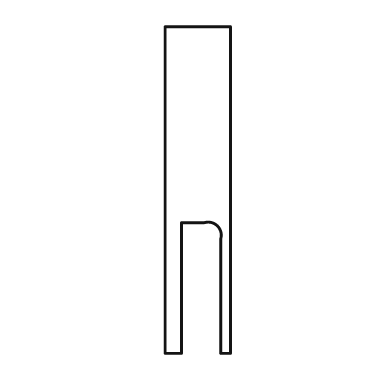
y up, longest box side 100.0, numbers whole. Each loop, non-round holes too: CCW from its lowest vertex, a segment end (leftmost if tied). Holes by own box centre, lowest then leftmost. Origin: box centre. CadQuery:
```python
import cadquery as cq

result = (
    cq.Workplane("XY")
    .moveTo(-10.0, -50.0)
    .lineTo(-5.0, -50.0)
    .lineTo(-5.0, -10.0)
    .lineTo(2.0, -10.0)
    .threePointArc((6.0, -11.0), (7.0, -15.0))
    .lineTo(7.0, -50.0)
    .lineTo(10.0, -50.0)
    .lineTo(10.0, 50.0)
    .lineTo(-10.0, 50.0)
    .close()
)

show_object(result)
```